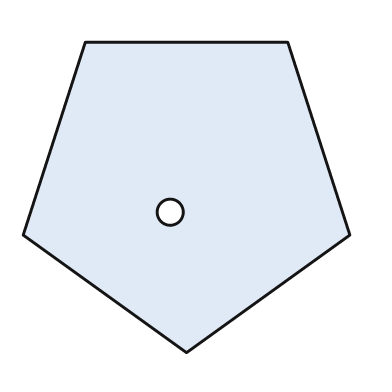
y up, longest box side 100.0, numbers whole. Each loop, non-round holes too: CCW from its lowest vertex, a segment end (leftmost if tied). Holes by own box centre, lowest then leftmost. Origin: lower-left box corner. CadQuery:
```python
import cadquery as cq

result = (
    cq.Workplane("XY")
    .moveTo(50.0, 0.0)
    .lineTo(100.0, 36.0)
    .lineTo(81.0, 95.0)
    .lineTo(19.0, 95.0)
    .lineTo(0.0, 36.0)
    .close()
    .moveTo(45.0, 43.0)
    .circle(4.0)
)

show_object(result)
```